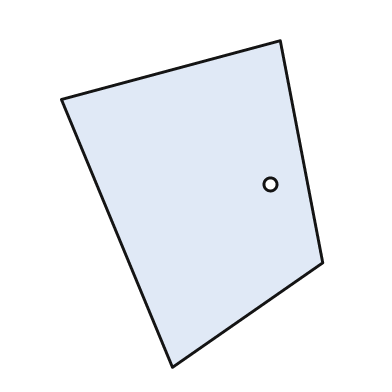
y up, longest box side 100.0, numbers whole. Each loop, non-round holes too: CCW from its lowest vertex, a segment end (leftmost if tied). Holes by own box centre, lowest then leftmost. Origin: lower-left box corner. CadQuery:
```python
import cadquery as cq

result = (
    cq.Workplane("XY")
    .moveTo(34.0, 0.0)
    .lineTo(80.0, 32.0)
    .lineTo(67.0, 100.0)
    .lineTo(0.0, 82.0)
    .close()
    .moveTo(64.0, 56.0)
    .circle(2.0)
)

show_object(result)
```